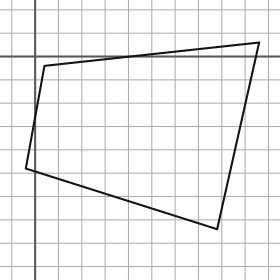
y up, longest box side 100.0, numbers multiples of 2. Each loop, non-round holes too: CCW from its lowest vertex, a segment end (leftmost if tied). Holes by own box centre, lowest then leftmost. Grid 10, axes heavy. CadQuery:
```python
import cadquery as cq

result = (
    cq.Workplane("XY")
    .moveTo(78.0, -74.0)
    .lineTo(96.0, 6.0)
    .lineTo(4.0, -4.0)
    .lineTo(-4.0, -48.0)
    .close()
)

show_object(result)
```